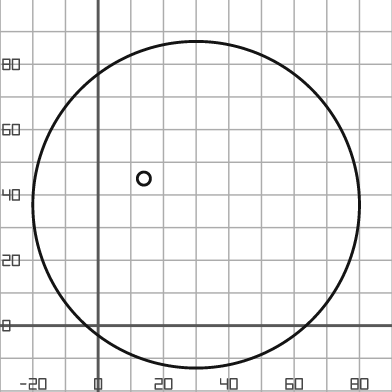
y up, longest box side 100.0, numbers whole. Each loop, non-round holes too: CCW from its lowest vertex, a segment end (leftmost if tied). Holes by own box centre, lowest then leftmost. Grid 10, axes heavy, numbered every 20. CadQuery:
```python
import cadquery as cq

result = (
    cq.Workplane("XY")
    .moveTo(30.0, 37.0)
    .circle(50.0)
    .moveTo(14.0, 45.0)
    .circle(2.0)
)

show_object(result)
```